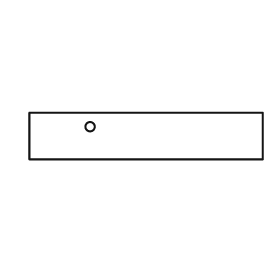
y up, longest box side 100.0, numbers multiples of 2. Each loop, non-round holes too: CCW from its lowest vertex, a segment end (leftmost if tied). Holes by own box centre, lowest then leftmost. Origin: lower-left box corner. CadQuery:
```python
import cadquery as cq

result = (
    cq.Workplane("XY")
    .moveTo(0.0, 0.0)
    .lineTo(100.0, 0.0)
    .lineTo(100.0, 20.0)
    .lineTo(0.0, 20.0)
    .close()
    .moveTo(26.0, 14.0)
    .circle(2.0)
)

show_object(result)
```